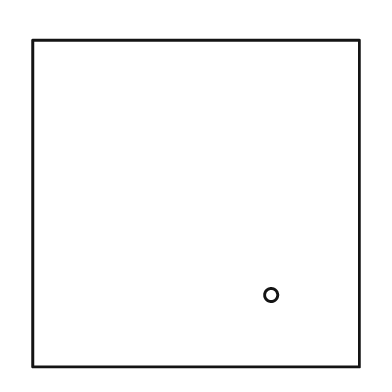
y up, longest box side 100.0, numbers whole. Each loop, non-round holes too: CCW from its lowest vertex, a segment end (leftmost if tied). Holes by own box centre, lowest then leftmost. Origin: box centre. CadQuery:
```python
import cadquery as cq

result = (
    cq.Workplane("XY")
    .moveTo(-50.0, -50.0)
    .lineTo(50.0, -50.0)
    .lineTo(50.0, 50.0)
    .lineTo(-50.0, 50.0)
    .close()
    .moveTo(23.0, -28.0)
    .circle(2.0)
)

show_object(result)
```